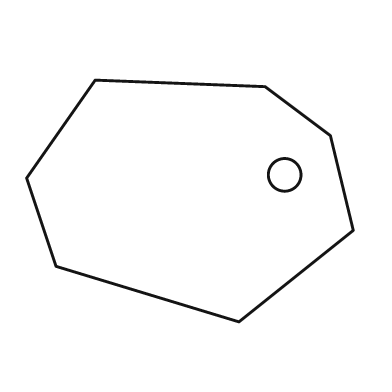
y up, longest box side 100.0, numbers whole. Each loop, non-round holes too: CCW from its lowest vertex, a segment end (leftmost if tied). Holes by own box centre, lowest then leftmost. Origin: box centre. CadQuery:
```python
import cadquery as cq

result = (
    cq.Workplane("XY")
    .moveTo(15.0, -37.0)
    .lineTo(50.0, -9.0)
    .lineTo(43.0, 20.0)
    .lineTo(23.0, 35.0)
    .lineTo(-29.0, 37.0)
    .lineTo(-50.0, 7.0)
    .lineTo(-41.0, -20.0)
    .close()
    .moveTo(29.0, 8.0)
    .circle(5.0)
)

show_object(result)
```